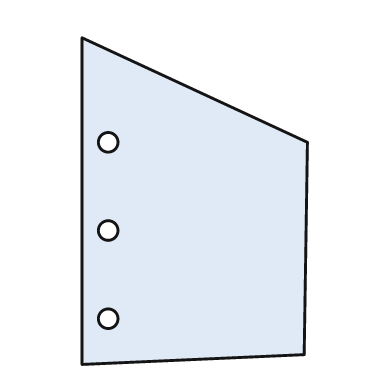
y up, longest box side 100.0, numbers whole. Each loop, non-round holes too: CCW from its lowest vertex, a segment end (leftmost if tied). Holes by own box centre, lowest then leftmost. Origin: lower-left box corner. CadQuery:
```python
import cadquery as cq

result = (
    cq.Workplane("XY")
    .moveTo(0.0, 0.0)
    .lineTo(68.0, 3.0)
    .lineTo(69.0, 68.0)
    .lineTo(0.0, 100.0)
    .close()
    .moveTo(8.0, 14.0)
    .circle(3.0)
    .moveTo(8.0, 41.0)
    .circle(3.0)
    .moveTo(8.0, 68.0)
    .circle(3.0)
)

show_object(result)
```